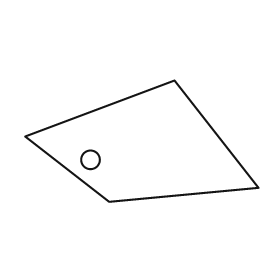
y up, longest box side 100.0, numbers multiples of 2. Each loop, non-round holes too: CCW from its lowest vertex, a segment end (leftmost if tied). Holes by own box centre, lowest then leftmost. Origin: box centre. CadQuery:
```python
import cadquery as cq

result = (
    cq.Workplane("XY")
    .moveTo(-14.0, -26.0)
    .lineTo(50.0, -20.0)
    .lineTo(14.0, 26.0)
    .lineTo(-50.0, 2.0)
    .close()
    .moveTo(-22.0, -8.0)
    .circle(4.0)
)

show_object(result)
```